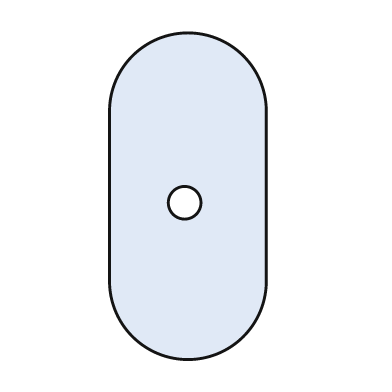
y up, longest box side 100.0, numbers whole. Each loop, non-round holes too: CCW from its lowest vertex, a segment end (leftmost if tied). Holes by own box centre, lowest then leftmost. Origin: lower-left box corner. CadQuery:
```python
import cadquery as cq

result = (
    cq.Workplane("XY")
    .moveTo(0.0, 24.0)
    .threePointArc((24.0, 0.0), (48.0, 24.0))
    .lineTo(48.0, 76.0)
    .threePointArc((24.0, 100.0), (0.0, 76.0))
    .close()
    .moveTo(23.0, 48.0)
    .circle(5.0)
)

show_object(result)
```